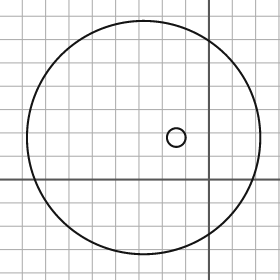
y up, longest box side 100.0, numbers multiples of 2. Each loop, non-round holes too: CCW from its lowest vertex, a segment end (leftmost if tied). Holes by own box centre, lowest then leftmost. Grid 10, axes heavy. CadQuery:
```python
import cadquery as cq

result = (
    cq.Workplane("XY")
    .moveTo(-28.0, 18.0)
    .circle(50.0)
    .moveTo(-14.0, 18.0)
    .circle(4.0)
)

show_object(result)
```